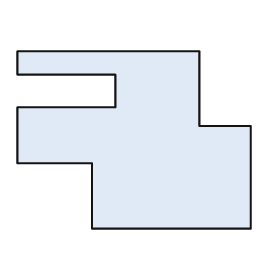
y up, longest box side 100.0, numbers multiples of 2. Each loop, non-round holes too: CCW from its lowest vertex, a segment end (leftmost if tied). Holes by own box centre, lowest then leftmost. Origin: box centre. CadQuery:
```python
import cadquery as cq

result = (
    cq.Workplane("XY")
    .moveTo(-18.0, -38.0)
    .lineTo(50.0, -38.0)
    .lineTo(50.0, 6.0)
    .lineTo(28.0, 6.0)
    .lineTo(28.0, 38.0)
    .lineTo(-50.0, 38.0)
    .lineTo(-50.0, 28.0)
    .lineTo(-8.0, 28.0)
    .lineTo(-8.0, 14.0)
    .lineTo(-50.0, 14.0)
    .lineTo(-50.0, -10.0)
    .lineTo(-18.0, -10.0)
    .close()
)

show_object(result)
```